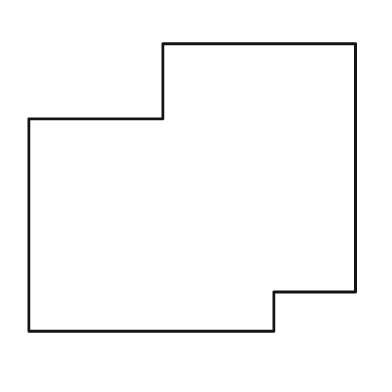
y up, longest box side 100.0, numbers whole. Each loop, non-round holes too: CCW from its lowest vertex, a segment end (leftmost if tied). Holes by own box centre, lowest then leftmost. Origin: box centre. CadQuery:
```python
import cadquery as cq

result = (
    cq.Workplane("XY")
    .moveTo(-50.0, -44.0)
    .lineTo(25.0, -44.0)
    .lineTo(25.0, -32.0)
    .lineTo(50.0, -32.0)
    .lineTo(50.0, 44.0)
    .lineTo(-9.0, 44.0)
    .lineTo(-9.0, 21.0)
    .lineTo(-50.0, 21.0)
    .close()
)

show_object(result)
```